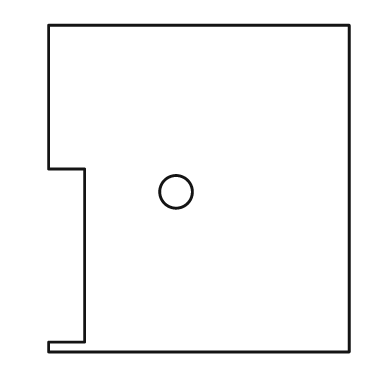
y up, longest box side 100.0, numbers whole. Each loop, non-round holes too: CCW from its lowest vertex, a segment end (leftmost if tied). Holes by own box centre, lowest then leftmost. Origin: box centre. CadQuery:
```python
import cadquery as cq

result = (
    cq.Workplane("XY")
    .moveTo(-46.0, -50.0)
    .lineTo(46.0, -50.0)
    .lineTo(46.0, 50.0)
    .lineTo(-46.0, 50.0)
    .lineTo(-46.0, 6.0)
    .lineTo(-35.0, 6.0)
    .lineTo(-35.0, -47.0)
    .lineTo(-46.0, -47.0)
    .close()
    .moveTo(-7.0, -1.0)
    .circle(5.0)
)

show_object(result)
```